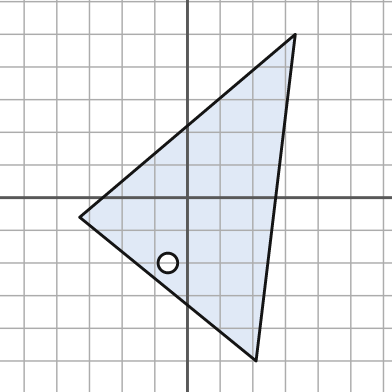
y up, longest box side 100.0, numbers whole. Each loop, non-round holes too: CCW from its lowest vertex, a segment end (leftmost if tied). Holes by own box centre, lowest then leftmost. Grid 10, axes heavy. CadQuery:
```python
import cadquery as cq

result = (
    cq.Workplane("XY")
    .moveTo(21.0, -50.0)
    .lineTo(33.0, 50.0)
    .lineTo(-33.0, -6.0)
    .close()
    .moveTo(-6.0, -20.0)
    .circle(3.0)
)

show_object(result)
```